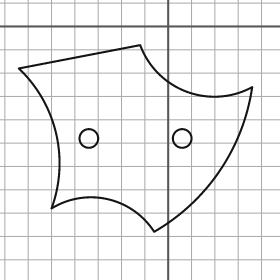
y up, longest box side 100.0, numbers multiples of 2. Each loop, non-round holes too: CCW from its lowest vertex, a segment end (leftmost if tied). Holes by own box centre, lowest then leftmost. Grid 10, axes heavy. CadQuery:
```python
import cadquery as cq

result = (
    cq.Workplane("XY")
    .moveTo(-6.0, -88.0)
    .threePointArc((22.0, -62.0), (36.0, -26.0))
    .threePointArc((8.0, -28.0), (-12.0, -8.0))
    .lineTo(-64.0, -18.0)
    .threePointArc((-48.0, -46.0), (-50.0, -78.0))
    .threePointArc((-26.0, -74.0), (-6.0, -88.0))
    .close()
    .moveTo(-34.0, -48.0)
    .circle(4.0)
    .moveTo(6.0, -48.0)
    .circle(4.0)
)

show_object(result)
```